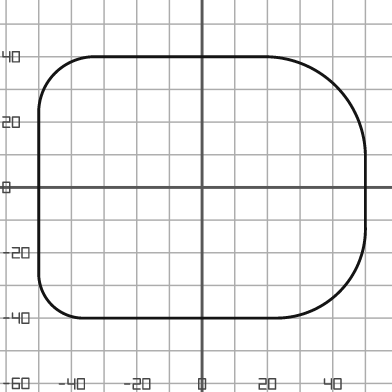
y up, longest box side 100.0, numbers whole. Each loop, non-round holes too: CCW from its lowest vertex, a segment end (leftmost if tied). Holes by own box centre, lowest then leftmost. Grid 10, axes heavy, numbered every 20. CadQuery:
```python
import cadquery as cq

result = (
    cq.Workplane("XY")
    .moveTo(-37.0, -40.0)
    .lineTo(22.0, -40.0)
    .threePointArc((42.0, -32.0), (50.0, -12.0))
    .lineTo(50.0, 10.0)
    .threePointArc((41.0, 31.0), (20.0, 40.0))
    .lineTo(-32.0, 40.0)
    .threePointArc((-45.0, 35.0), (-50.0, 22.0))
    .lineTo(-50.0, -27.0)
    .threePointArc((-46.0, -36.0), (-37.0, -40.0))
    .close()
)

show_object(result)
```